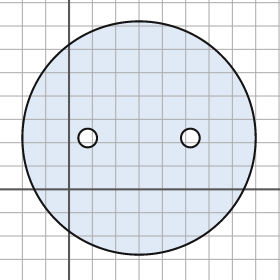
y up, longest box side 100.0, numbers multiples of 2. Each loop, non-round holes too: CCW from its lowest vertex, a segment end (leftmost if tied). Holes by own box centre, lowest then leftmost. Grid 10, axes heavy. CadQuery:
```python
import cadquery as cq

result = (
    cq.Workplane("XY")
    .moveTo(30.0, 22.0)
    .circle(50.0)
    .moveTo(8.0, 22.0)
    .circle(4.0)
    .moveTo(52.0, 22.0)
    .circle(4.0)
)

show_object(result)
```